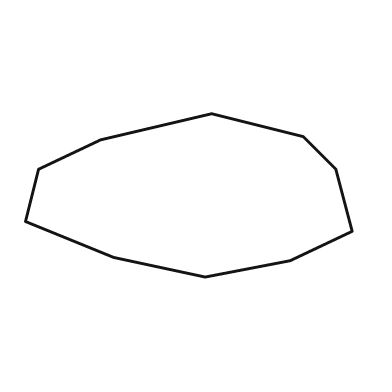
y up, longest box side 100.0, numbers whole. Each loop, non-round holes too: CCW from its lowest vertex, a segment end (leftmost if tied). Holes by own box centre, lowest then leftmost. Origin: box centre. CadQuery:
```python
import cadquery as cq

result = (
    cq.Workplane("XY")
    .moveTo(5.0, -25.0)
    .lineTo(31.0, -20.0)
    .lineTo(50.0, -11.0)
    .lineTo(45.0, 8.0)
    .lineTo(35.0, 18.0)
    .lineTo(7.0, 25.0)
    .lineTo(-27.0, 17.0)
    .lineTo(-46.0, 8.0)
    .lineTo(-50.0, -8.0)
    .lineTo(-23.0, -19.0)
    .close()
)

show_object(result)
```